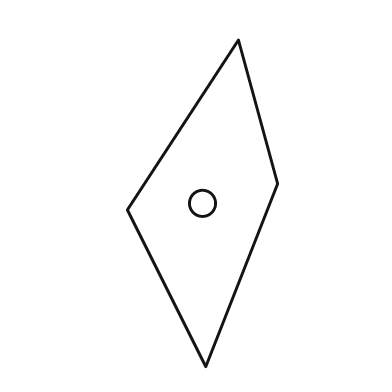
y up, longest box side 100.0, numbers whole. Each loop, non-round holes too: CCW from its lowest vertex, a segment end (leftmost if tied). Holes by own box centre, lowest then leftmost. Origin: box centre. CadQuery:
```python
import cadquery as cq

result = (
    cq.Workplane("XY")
    .moveTo(1.0, -50.0)
    .lineTo(23.0, 6.0)
    .lineTo(11.0, 50.0)
    .lineTo(-23.0, -2.0)
    .close()
    .moveTo(0.0, 0.0)
    .circle(4.0)
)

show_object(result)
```